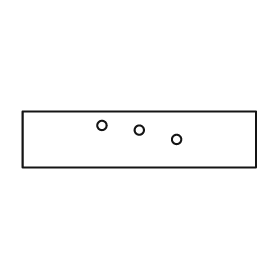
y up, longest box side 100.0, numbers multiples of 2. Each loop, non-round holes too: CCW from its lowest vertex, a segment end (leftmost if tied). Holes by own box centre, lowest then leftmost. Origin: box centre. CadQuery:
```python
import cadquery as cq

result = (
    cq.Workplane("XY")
    .moveTo(-50.0, -12.0)
    .lineTo(50.0, -12.0)
    .lineTo(50.0, 12.0)
    .lineTo(-50.0, 12.0)
    .close()
    .moveTo(16.0, 0.0)
    .circle(2.0)
    .moveTo(0.0, 4.0)
    .circle(2.0)
    .moveTo(-16.0, 6.0)
    .circle(2.0)
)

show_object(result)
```